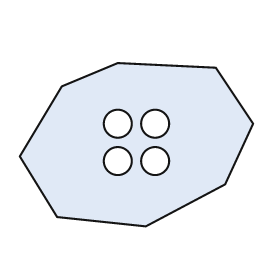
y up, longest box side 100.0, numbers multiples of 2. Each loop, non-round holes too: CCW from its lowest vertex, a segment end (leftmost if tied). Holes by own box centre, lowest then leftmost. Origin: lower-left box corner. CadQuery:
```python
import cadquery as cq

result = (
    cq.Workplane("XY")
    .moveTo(54.0, 0.0)
    .lineTo(88.0, 18.0)
    .lineTo(100.0, 44.0)
    .lineTo(84.0, 68.0)
    .lineTo(42.0, 70.0)
    .lineTo(18.0, 60.0)
    .lineTo(0.0, 30.0)
    .lineTo(16.0, 4.0)
    .close()
    .moveTo(42.0, 28.0)
    .circle(6.0)
    .moveTo(58.0, 28.0)
    .circle(6.0)
    .moveTo(42.0, 44.0)
    .circle(6.0)
    .moveTo(58.0, 44.0)
    .circle(6.0)
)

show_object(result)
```